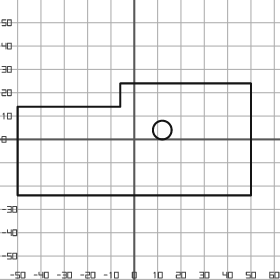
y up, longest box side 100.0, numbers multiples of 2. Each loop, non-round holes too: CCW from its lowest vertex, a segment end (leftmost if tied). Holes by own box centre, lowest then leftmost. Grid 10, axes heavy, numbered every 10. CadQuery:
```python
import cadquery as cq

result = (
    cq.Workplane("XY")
    .moveTo(-50.0, -24.0)
    .lineTo(50.0, -24.0)
    .lineTo(50.0, 24.0)
    .lineTo(-6.0, 24.0)
    .lineTo(-6.0, 14.0)
    .lineTo(-50.0, 14.0)
    .close()
    .moveTo(12.0, 4.0)
    .circle(4.0)
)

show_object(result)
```